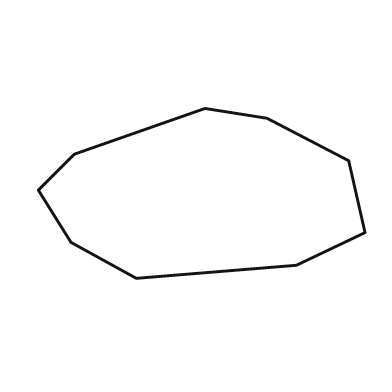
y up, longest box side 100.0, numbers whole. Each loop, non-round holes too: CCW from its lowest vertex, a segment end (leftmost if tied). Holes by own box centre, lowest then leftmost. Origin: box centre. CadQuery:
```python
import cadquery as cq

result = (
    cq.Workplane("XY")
    .moveTo(-20.0, -26.0)
    .lineTo(29.0, -22.0)
    .lineTo(50.0, -12.0)
    .lineTo(45.0, 10.0)
    .lineTo(20.0, 23.0)
    .lineTo(1.0, 26.0)
    .lineTo(-39.0, 12.0)
    .lineTo(-50.0, 1.0)
    .lineTo(-40.0, -15.0)
    .close()
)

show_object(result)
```